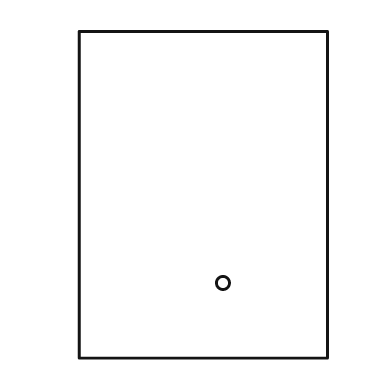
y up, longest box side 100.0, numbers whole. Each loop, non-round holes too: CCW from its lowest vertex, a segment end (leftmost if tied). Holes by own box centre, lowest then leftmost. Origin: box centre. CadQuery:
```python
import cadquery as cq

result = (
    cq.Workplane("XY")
    .moveTo(-38.0, -50.0)
    .lineTo(38.0, -50.0)
    .lineTo(38.0, 50.0)
    .lineTo(-38.0, 50.0)
    .close()
    .moveTo(6.0, -27.0)
    .circle(2.0)
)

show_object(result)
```